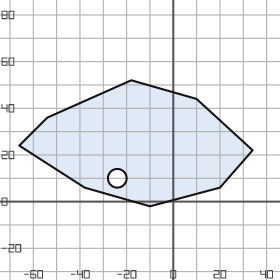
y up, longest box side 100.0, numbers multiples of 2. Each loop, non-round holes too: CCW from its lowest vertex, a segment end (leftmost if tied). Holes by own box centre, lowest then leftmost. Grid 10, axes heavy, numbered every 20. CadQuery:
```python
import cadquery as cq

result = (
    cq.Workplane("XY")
    .moveTo(-10.0, -2.0)
    .lineTo(20.0, 6.0)
    .lineTo(34.0, 22.0)
    .lineTo(10.0, 44.0)
    .lineTo(-18.0, 52.0)
    .lineTo(-54.0, 36.0)
    .lineTo(-66.0, 24.0)
    .lineTo(-38.0, 6.0)
    .close()
    .moveTo(-24.0, 10.0)
    .circle(4.0)
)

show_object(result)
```